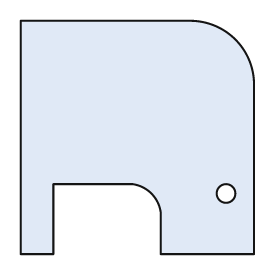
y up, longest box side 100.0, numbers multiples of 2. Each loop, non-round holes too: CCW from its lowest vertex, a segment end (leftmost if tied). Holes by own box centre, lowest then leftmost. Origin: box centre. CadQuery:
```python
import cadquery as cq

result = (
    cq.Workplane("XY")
    .moveTo(-50.0, -50.0)
    .lineTo(-36.0, -50.0)
    .lineTo(-36.0, -20.0)
    .lineTo(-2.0, -20.0)
    .threePointArc((6.0, -24.0), (10.0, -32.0))
    .lineTo(10.0, -50.0)
    .lineTo(50.0, -50.0)
    .lineTo(50.0, 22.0)
    .threePointArc((42.0, 42.0), (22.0, 50.0))
    .lineTo(-50.0, 50.0)
    .close()
    .moveTo(38.0, -24.0)
    .circle(4.0)
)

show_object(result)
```